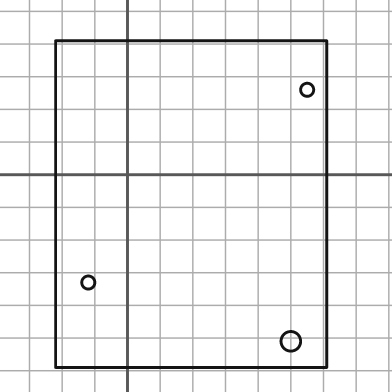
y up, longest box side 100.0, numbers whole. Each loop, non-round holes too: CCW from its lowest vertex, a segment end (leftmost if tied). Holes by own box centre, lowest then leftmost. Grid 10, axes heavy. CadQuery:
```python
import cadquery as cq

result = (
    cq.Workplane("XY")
    .moveTo(-22.0, -59.0)
    .lineTo(61.0, -59.0)
    .lineTo(61.0, 41.0)
    .lineTo(-22.0, 41.0)
    .close()
    .moveTo(50.0, -51.0)
    .circle(3.0)
    .moveTo(-12.0, -33.0)
    .circle(2.0)
    .moveTo(55.0, 26.0)
    .circle(2.0)
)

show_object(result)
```